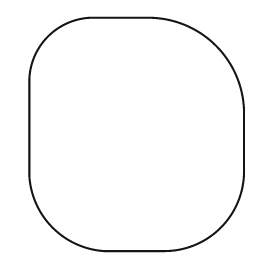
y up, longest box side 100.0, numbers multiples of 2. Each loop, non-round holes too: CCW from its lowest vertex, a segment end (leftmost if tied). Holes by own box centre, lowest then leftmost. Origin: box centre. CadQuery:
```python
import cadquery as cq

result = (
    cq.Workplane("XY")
    .moveTo(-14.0, -50.0)
    .lineTo(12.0, -50.0)
    .threePointArc((36.0, -40.0), (46.0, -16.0))
    .lineTo(46.0, 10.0)
    .threePointArc((34.0, 38.0), (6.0, 50.0))
    .lineTo(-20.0, 50.0)
    .threePointArc((-38.0, 42.0), (-46.0, 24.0))
    .lineTo(-46.0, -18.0)
    .threePointArc((-36.0, -40.0), (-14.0, -50.0))
    .close()
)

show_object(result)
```